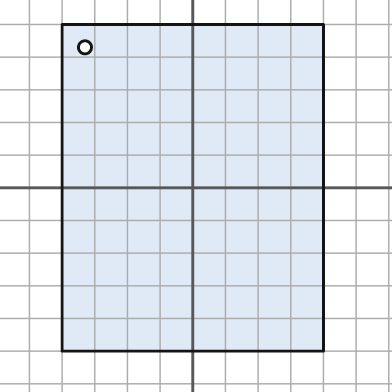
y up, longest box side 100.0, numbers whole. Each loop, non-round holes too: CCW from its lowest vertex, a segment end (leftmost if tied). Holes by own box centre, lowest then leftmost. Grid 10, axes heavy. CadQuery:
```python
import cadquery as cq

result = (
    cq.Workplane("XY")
    .moveTo(-40.0, -50.0)
    .lineTo(40.0, -50.0)
    .lineTo(40.0, 50.0)
    .lineTo(-40.0, 50.0)
    .close()
    .moveTo(-33.0, 43.0)
    .circle(2.0)
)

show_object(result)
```